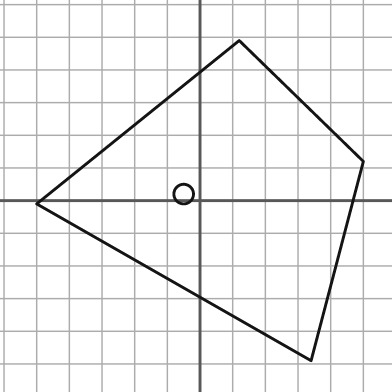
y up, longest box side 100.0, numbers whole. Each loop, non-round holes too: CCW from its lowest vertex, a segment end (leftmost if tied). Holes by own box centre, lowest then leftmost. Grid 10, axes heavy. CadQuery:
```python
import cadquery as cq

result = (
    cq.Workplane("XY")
    .moveTo(34.0, -49.0)
    .lineTo(50.0, 12.0)
    .lineTo(12.0, 49.0)
    .lineTo(-50.0, -1.0)
    .close()
    .moveTo(-5.0, 2.0)
    .circle(3.0)
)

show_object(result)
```